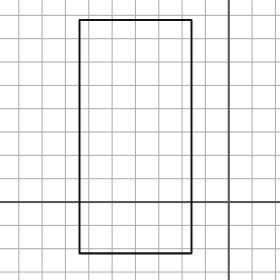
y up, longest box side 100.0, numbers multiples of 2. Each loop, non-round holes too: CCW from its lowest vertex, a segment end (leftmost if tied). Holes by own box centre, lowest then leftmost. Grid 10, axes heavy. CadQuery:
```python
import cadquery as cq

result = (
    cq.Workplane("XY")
    .moveTo(-64.0, -22.0)
    .lineTo(-16.0, -22.0)
    .lineTo(-16.0, 78.0)
    .lineTo(-64.0, 78.0)
    .close()
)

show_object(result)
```